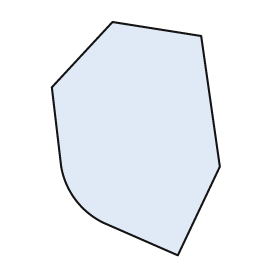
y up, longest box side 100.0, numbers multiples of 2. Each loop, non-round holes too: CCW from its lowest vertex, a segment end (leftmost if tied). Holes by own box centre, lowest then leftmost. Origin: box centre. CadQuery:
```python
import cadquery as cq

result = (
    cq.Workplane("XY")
    .moveTo(18.0, -50.0)
    .lineTo(36.0, -12.0)
    .lineTo(28.0, 44.0)
    .lineTo(-10.0, 50.0)
    .lineTo(-36.0, 22.0)
    .lineTo(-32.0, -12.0)
    .threePointArc((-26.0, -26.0), (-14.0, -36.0))
    .close()
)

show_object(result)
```